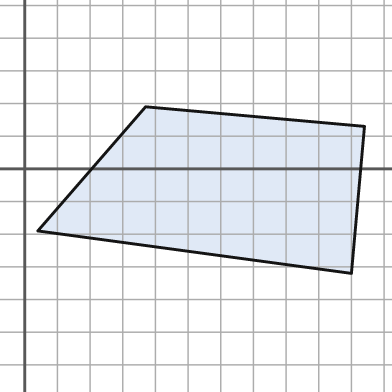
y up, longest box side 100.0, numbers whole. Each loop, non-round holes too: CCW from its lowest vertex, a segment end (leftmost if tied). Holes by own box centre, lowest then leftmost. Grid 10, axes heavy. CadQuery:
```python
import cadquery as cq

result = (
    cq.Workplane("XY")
    .moveTo(100.0, -32.0)
    .lineTo(104.0, 13.0)
    .lineTo(37.0, 19.0)
    .lineTo(4.0, -19.0)
    .close()
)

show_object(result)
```